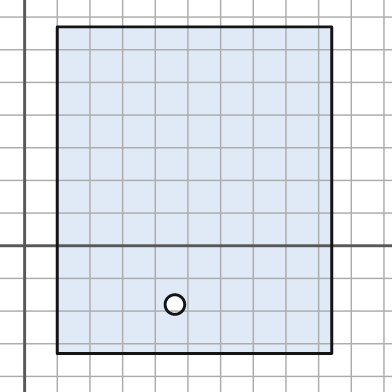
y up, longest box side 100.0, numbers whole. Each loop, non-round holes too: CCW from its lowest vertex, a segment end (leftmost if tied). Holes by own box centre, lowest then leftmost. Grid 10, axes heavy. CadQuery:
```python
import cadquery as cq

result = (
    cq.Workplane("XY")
    .moveTo(10.0, -33.0)
    .lineTo(94.0, -33.0)
    .lineTo(94.0, 67.0)
    .lineTo(10.0, 67.0)
    .close()
    .moveTo(46.0, -18.0)
    .circle(3.0)
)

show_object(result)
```